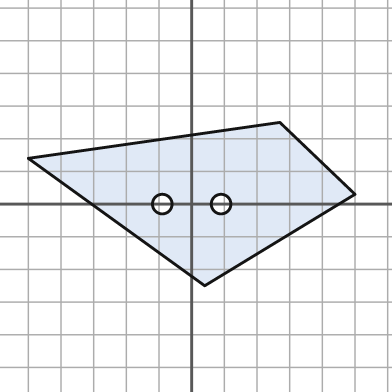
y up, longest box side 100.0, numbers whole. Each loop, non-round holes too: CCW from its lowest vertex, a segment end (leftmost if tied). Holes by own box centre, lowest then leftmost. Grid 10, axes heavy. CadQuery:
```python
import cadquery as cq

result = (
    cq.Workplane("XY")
    .moveTo(4.0, -25.0)
    .lineTo(50.0, 3.0)
    .lineTo(27.0, 25.0)
    .lineTo(-50.0, 14.0)
    .close()
    .moveTo(-9.0, 0.0)
    .circle(3.0)
    .moveTo(9.0, 0.0)
    .circle(3.0)
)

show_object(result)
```